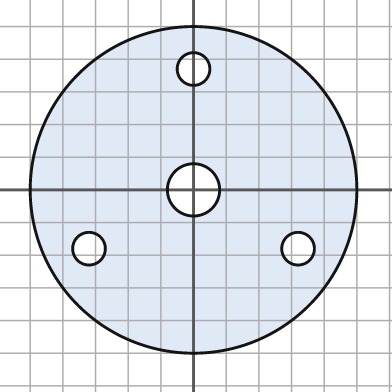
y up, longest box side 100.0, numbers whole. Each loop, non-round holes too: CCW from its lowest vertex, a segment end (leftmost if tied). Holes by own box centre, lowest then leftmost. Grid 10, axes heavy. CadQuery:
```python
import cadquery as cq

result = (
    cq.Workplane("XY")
    .moveTo(0.0, 0.0)
    .circle(50.0)
    .moveTo(-32.0, -18.0)
    .circle(5.0)
    .moveTo(32.0, -18.0)
    .circle(5.0)
    .moveTo(0.0, 0.0)
    .circle(8.0)
    .moveTo(0.0, 37.0)
    .circle(5.0)
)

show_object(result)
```